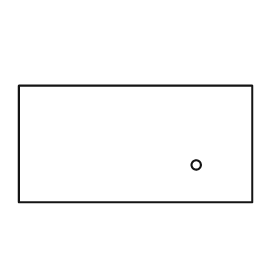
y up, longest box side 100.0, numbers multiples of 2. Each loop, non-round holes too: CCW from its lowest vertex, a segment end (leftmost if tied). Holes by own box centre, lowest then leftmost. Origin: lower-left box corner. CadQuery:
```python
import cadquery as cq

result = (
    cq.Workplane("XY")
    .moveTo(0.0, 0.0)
    .lineTo(100.0, 0.0)
    .lineTo(100.0, 50.0)
    .lineTo(0.0, 50.0)
    .close()
    .moveTo(76.0, 16.0)
    .circle(2.0)
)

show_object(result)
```